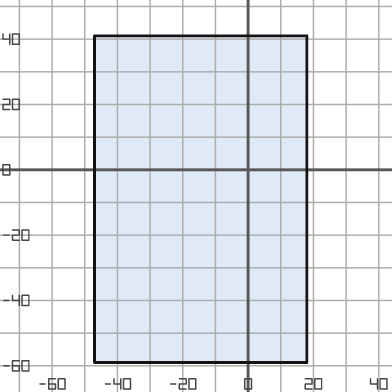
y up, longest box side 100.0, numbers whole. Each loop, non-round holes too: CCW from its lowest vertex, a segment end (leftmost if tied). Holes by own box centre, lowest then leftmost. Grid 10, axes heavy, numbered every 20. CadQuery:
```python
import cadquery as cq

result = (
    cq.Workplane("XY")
    .moveTo(-47.0, -59.0)
    .lineTo(18.0, -59.0)
    .lineTo(18.0, 41.0)
    .lineTo(-47.0, 41.0)
    .close()
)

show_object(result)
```